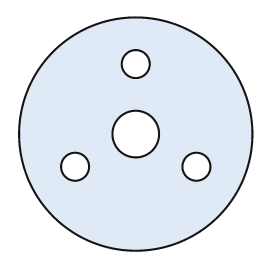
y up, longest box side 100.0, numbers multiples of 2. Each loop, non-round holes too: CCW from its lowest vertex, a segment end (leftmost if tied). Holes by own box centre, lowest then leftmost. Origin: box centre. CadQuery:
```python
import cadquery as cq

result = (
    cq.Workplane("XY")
    .moveTo(0.0, 0.0)
    .circle(50.0)
    .moveTo(-26.0, -14.0)
    .circle(6.0)
    .moveTo(26.0, -14.0)
    .circle(6.0)
    .moveTo(0.0, 0.0)
    .circle(10.0)
    .moveTo(0.0, 30.0)
    .circle(6.0)
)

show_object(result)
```